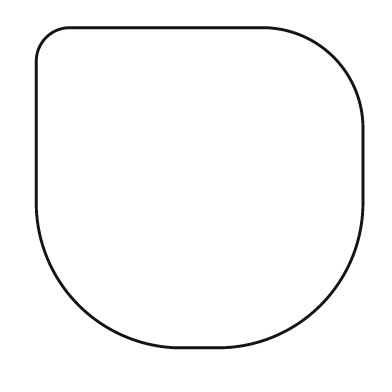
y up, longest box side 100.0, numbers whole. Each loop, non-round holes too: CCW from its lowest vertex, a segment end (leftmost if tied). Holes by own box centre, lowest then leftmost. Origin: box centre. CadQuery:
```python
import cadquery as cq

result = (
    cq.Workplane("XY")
    .moveTo(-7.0, -49.0)
    .lineTo(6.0, -49.0)
    .threePointArc((37.0, -36.0), (50.0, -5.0))
    .lineTo(50.0, 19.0)
    .threePointArc((41.0, 40.0), (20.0, 49.0))
    .lineTo(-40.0, 49.0)
    .threePointArc((-47.0, 46.0), (-50.0, 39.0))
    .lineTo(-50.0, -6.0)
    .threePointArc((-37.0, -36.0), (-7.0, -49.0))
    .close()
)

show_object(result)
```